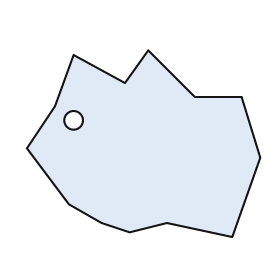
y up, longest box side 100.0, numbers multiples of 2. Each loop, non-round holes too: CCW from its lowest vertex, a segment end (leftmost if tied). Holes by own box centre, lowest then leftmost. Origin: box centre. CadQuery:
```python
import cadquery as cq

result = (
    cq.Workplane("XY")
    .moveTo(38.0, -40.0)
    .lineTo(50.0, -6.0)
    .lineTo(42.0, 20.0)
    .lineTo(22.0, 20.0)
    .lineTo(2.0, 40.0)
    .lineTo(-8.0, 26.0)
    .lineTo(-30.0, 38.0)
    .lineTo(-38.0, 16.0)
    .lineTo(-50.0, -2.0)
    .lineTo(-32.0, -26.0)
    .lineTo(-18.0, -34.0)
    .lineTo(-6.0, -38.0)
    .lineTo(10.0, -34.0)
    .close()
    .moveTo(-30.0, 10.0)
    .circle(4.0)
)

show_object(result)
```